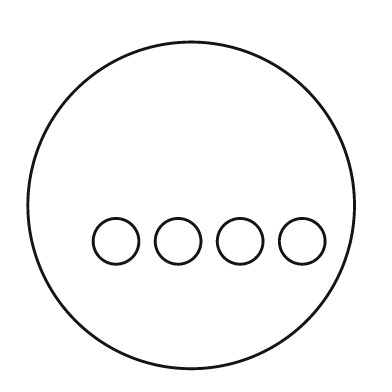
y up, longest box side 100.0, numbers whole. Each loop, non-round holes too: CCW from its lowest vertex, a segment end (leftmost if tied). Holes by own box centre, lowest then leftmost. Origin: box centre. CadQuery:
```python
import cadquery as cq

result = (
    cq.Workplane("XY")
    .moveTo(0.0, 0.0)
    .circle(50.0)
    .moveTo(-23.0, -11.0)
    .circle(7.0)
    .moveTo(-4.0, -11.0)
    .circle(7.0)
    .moveTo(15.0, -11.0)
    .circle(7.0)
    .moveTo(34.0, -11.0)
    .circle(7.0)
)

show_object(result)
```